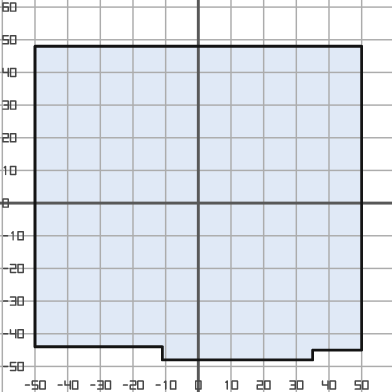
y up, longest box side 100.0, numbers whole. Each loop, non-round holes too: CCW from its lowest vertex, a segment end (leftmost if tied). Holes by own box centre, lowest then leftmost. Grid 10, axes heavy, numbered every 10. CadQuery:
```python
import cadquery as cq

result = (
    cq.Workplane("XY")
    .moveTo(-11.0, -48.0)
    .lineTo(35.0, -48.0)
    .lineTo(35.0, -45.0)
    .lineTo(50.0, -45.0)
    .lineTo(50.0, 48.0)
    .lineTo(-50.0, 48.0)
    .lineTo(-50.0, -44.0)
    .lineTo(-11.0, -44.0)
    .close()
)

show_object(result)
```